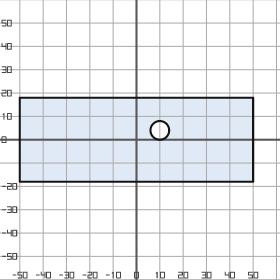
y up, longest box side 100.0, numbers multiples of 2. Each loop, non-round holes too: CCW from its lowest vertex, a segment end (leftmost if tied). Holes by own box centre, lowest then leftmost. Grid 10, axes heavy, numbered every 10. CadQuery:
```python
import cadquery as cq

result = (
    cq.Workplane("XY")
    .moveTo(-50.0, -18.0)
    .lineTo(50.0, -18.0)
    .lineTo(50.0, 18.0)
    .lineTo(-50.0, 18.0)
    .close()
    .moveTo(10.0, 4.0)
    .circle(4.0)
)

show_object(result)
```